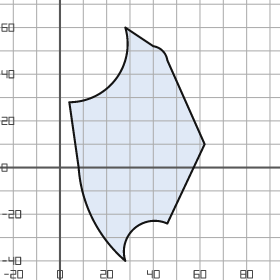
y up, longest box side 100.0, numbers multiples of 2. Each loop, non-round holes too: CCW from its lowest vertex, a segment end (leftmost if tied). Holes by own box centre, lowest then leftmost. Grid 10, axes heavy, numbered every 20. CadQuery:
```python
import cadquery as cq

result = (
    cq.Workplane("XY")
    .moveTo(28.0, -40.0)
    .threePointArc((32.0, -26.0), (46.0, -24.0))
    .lineTo(62.0, 10.0)
    .lineTo(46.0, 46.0)
    .threePointArc((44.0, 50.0), (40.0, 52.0))
    .lineTo(28.0, 60.0)
    .threePointArc((24.0, 38.0), (4.0, 28.0))
    .lineTo(8.0, 0.0)
    .threePointArc((14.0, -22.0), (28.0, -40.0))
    .close()
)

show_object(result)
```